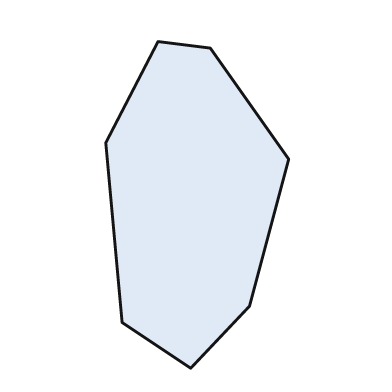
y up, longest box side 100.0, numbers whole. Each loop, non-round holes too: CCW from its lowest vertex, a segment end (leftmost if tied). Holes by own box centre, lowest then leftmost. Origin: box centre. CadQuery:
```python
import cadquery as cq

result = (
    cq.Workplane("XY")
    .moveTo(-2.0, -50.0)
    .lineTo(16.0, -31.0)
    .lineTo(28.0, 14.0)
    .lineTo(4.0, 48.0)
    .lineTo(-12.0, 50.0)
    .lineTo(-28.0, 19.0)
    .lineTo(-23.0, -36.0)
    .close()
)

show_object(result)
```